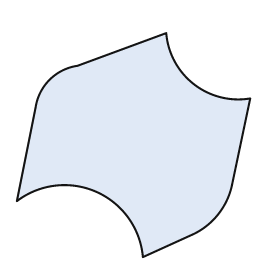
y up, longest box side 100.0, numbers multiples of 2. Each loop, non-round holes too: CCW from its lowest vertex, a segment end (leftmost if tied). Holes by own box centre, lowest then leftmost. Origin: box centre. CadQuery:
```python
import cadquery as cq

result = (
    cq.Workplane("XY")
    .moveTo(4.0, -48.0)
    .lineTo(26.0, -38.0)
    .threePointArc((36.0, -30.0), (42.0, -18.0))
    .lineTo(50.0, 20.0)
    .threePointArc((26.0, 26.0), (14.0, 48.0))
    .lineTo(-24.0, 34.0)
    .threePointArc((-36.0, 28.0), (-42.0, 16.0))
    .lineTo(-50.0, -24.0)
    .threePointArc((-16.0, -20.0), (4.0, -48.0))
    .close()
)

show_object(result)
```